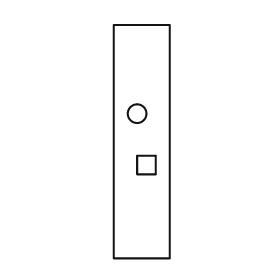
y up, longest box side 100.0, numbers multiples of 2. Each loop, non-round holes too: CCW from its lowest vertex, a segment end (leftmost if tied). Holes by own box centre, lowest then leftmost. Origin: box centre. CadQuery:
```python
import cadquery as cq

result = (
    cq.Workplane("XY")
    .moveTo(-12.0, -50.0)
    .lineTo(12.0, -50.0)
    .lineTo(12.0, 50.0)
    .lineTo(-12.0, 50.0)
    .close()
    .moveTo(-2.0, -14.0)
    .lineTo(6.0, -14.0)
    .lineTo(6.0, -6.0)
    .lineTo(-2.0, -6.0)
    .close()
    .moveTo(-2.0, 12.0)
    .circle(4.0)
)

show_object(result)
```